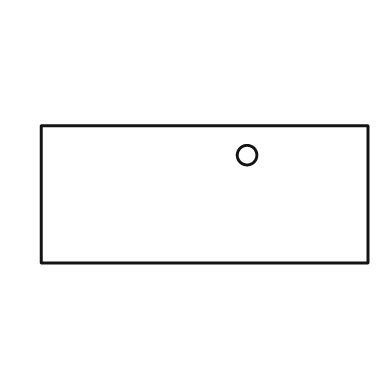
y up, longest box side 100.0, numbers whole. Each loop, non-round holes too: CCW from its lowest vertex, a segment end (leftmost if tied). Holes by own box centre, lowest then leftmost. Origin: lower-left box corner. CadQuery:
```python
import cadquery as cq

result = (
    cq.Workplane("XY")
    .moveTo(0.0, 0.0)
    .lineTo(100.0, 0.0)
    .lineTo(100.0, 42.0)
    .lineTo(0.0, 42.0)
    .close()
    .moveTo(63.0, 33.0)
    .circle(3.0)
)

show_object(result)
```